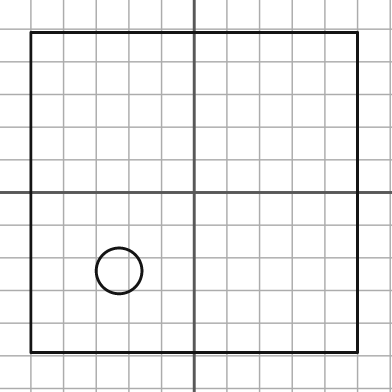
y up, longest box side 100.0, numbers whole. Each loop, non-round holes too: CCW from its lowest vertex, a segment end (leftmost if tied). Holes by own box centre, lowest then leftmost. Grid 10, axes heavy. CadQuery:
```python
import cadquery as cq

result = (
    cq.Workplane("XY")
    .moveTo(-50.0, -49.0)
    .lineTo(50.0, -49.0)
    .lineTo(50.0, 49.0)
    .lineTo(-50.0, 49.0)
    .close()
    .moveTo(-23.0, -24.0)
    .circle(7.0)
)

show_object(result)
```